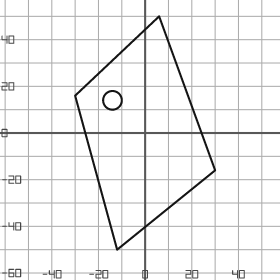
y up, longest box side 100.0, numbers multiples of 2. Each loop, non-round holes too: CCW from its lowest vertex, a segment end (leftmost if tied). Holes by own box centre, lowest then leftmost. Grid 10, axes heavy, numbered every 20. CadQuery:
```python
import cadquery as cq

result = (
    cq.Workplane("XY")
    .moveTo(-12.0, -50.0)
    .lineTo(30.0, -16.0)
    .lineTo(6.0, 50.0)
    .lineTo(-30.0, 16.0)
    .close()
    .moveTo(-14.0, 14.0)
    .circle(4.0)
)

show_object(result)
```